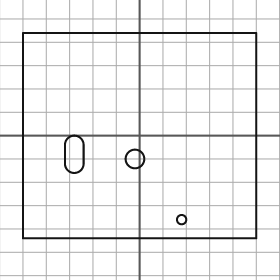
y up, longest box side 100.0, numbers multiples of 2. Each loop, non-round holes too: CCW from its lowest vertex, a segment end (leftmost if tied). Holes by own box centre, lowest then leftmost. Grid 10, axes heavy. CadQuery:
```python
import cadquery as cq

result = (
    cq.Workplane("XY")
    .moveTo(-50.0, -44.0)
    .lineTo(50.0, -44.0)
    .lineTo(50.0, 44.0)
    .lineTo(-50.0, 44.0)
    .close()
    .moveTo(18.0, -36.0)
    .circle(2.0)
    .moveTo(-2.0, -10.0)
    .circle(4.0)
    .moveTo(-32.0, -12.0)
    .threePointArc((-28.0, -16.0), (-24.0, -12.0))
    .lineTo(-24.0, -4.0)
    .threePointArc((-28.0, 0.0), (-32.0, -4.0))
    .close()
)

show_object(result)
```